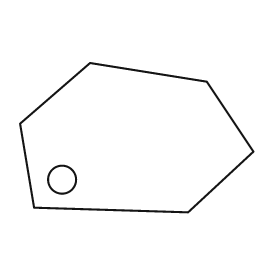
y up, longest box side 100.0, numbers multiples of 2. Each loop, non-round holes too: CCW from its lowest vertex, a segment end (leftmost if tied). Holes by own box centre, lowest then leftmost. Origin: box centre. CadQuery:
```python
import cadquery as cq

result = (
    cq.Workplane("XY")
    .moveTo(22.0, -32.0)
    .lineTo(50.0, -6.0)
    .lineTo(30.0, 24.0)
    .lineTo(-20.0, 32.0)
    .lineTo(-50.0, 6.0)
    .lineTo(-44.0, -30.0)
    .close()
    .moveTo(-32.0, -18.0)
    .circle(6.0)
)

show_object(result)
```